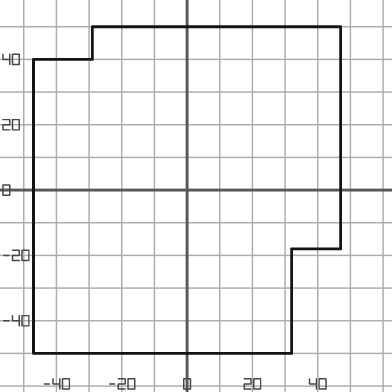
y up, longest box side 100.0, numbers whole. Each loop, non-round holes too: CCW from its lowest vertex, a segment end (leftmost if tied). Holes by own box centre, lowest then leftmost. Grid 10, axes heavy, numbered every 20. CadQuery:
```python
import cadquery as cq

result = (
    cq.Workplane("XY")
    .moveTo(-47.0, -50.0)
    .lineTo(32.0, -50.0)
    .lineTo(32.0, -18.0)
    .lineTo(47.0, -18.0)
    .lineTo(47.0, 50.0)
    .lineTo(-29.0, 50.0)
    .lineTo(-29.0, 40.0)
    .lineTo(-47.0, 40.0)
    .close()
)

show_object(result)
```